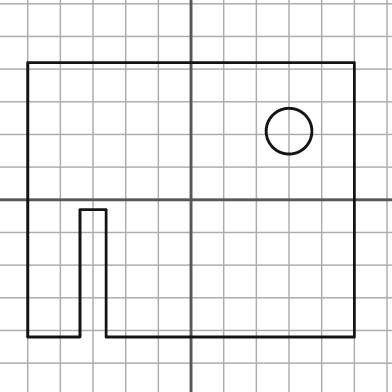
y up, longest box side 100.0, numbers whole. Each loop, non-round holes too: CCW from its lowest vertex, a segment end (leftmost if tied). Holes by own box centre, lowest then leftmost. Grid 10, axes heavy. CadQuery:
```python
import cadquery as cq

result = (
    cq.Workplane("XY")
    .moveTo(-50.0, -42.0)
    .lineTo(-34.0, -42.0)
    .lineTo(-34.0, -3.0)
    .lineTo(-26.0, -3.0)
    .lineTo(-26.0, -42.0)
    .lineTo(50.0, -42.0)
    .lineTo(50.0, 42.0)
    .lineTo(-50.0, 42.0)
    .close()
    .moveTo(30.0, 21.0)
    .circle(7.0)
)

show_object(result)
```